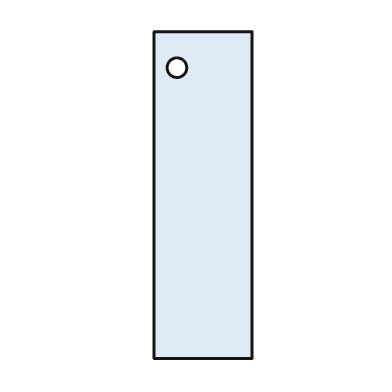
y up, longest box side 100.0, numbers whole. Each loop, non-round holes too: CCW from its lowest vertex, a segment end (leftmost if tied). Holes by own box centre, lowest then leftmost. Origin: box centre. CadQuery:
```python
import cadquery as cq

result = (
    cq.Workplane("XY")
    .moveTo(-15.0, -50.0)
    .lineTo(15.0, -50.0)
    .lineTo(15.0, 50.0)
    .lineTo(-15.0, 50.0)
    .close()
    .moveTo(-8.0, 39.0)
    .circle(3.0)
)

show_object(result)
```